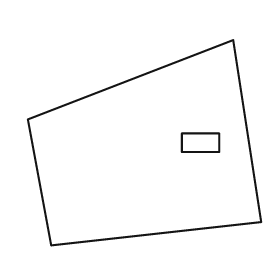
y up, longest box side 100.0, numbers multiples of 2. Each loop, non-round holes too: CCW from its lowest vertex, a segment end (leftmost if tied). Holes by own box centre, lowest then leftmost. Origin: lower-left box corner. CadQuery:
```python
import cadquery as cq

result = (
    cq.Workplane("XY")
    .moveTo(10.0, 0.0)
    .lineTo(100.0, 10.0)
    .lineTo(88.0, 88.0)
    .lineTo(0.0, 54.0)
    .close()
    .moveTo(66.0, 40.0)
    .lineTo(82.0, 40.0)
    .lineTo(82.0, 48.0)
    .lineTo(66.0, 48.0)
    .close()
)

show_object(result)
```